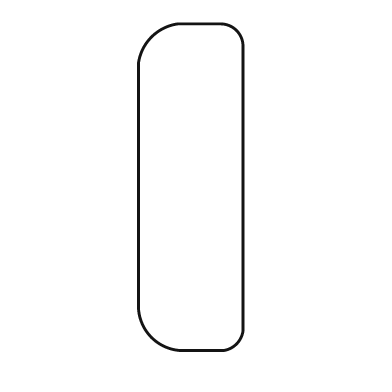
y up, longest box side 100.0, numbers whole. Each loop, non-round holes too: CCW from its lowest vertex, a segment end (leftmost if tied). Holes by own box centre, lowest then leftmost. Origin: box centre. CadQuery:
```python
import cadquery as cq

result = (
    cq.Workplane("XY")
    .moveTo(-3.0, -50.0)
    .lineTo(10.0, -50.0)
    .threePointArc((14.0, -48.0), (16.0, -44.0))
    .lineTo(16.0, 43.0)
    .threePointArc((14.0, 48.0), (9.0, 50.0))
    .lineTo(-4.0, 50.0)
    .threePointArc((-12.0, 46.0), (-16.0, 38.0))
    .lineTo(-16.0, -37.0)
    .threePointArc((-12.0, -46.0), (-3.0, -50.0))
    .close()
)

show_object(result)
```